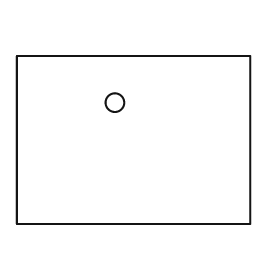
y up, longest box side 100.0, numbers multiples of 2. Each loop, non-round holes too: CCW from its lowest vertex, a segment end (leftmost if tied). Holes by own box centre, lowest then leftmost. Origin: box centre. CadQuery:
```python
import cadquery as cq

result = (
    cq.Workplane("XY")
    .moveTo(-50.0, -36.0)
    .lineTo(50.0, -36.0)
    .lineTo(50.0, 36.0)
    .lineTo(-50.0, 36.0)
    .close()
    .moveTo(-8.0, 16.0)
    .circle(4.0)
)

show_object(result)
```